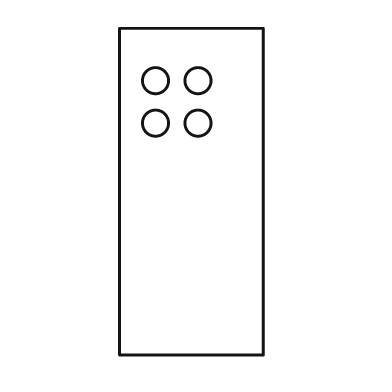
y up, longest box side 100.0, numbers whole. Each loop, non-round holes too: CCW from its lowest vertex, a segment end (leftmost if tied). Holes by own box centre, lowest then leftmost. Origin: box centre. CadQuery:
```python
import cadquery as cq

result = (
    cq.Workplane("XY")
    .moveTo(-22.0, -50.0)
    .lineTo(22.0, -50.0)
    .lineTo(22.0, 50.0)
    .lineTo(-22.0, 50.0)
    .close()
    .moveTo(-11.0, 21.0)
    .circle(4.0)
    .moveTo(2.0, 21.0)
    .circle(4.0)
    .moveTo(-11.0, 34.0)
    .circle(4.0)
    .moveTo(2.0, 34.0)
    .circle(4.0)
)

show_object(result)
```